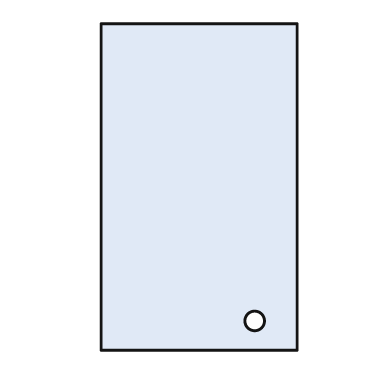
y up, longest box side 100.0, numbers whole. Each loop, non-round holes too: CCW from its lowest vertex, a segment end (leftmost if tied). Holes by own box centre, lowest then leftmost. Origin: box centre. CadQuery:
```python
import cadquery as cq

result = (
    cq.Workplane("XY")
    .moveTo(-30.0, -50.0)
    .lineTo(30.0, -50.0)
    .lineTo(30.0, 50.0)
    .lineTo(-30.0, 50.0)
    .close()
    .moveTo(17.0, -41.0)
    .circle(3.0)
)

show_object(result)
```